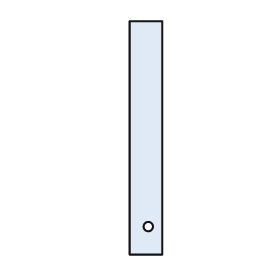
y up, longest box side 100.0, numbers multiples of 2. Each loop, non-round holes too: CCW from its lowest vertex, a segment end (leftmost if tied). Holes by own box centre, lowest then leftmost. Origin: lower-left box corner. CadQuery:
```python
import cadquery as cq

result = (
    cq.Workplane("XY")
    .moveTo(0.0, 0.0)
    .lineTo(14.0, 0.0)
    .lineTo(14.0, 100.0)
    .lineTo(0.0, 100.0)
    .close()
    .moveTo(8.0, 12.0)
    .circle(2.0)
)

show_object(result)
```